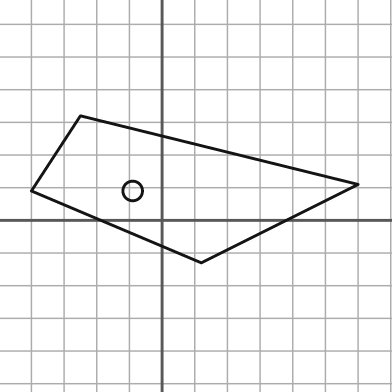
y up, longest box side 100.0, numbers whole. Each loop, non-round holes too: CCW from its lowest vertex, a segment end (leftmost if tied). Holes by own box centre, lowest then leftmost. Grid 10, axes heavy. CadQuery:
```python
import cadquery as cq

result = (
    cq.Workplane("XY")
    .moveTo(12.0, -13.0)
    .lineTo(60.0, 11.0)
    .lineTo(-25.0, 32.0)
    .lineTo(-40.0, 9.0)
    .close()
    .moveTo(-9.0, 9.0)
    .circle(3.0)
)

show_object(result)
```